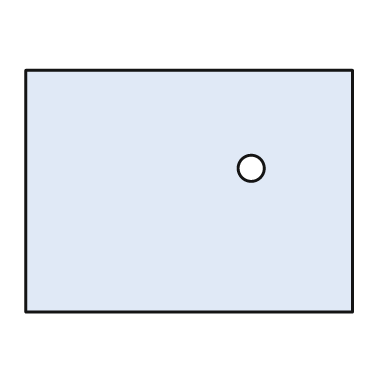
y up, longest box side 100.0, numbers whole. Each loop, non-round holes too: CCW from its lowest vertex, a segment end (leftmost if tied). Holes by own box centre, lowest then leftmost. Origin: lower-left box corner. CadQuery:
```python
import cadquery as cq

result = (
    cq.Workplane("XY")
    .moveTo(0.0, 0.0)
    .lineTo(100.0, 0.0)
    .lineTo(100.0, 74.0)
    .lineTo(0.0, 74.0)
    .close()
    .moveTo(69.0, 44.0)
    .circle(4.0)
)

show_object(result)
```